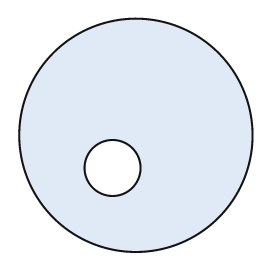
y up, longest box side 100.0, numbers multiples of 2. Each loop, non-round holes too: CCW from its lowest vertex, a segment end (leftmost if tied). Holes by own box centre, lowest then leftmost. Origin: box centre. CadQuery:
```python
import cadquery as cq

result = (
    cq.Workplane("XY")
    .moveTo(0.0, 0.0)
    .circle(50.0)
    .moveTo(-10.0, -14.0)
    .circle(12.0)
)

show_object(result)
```